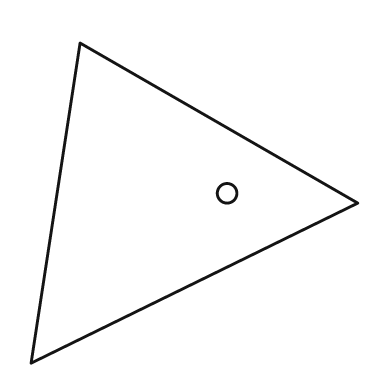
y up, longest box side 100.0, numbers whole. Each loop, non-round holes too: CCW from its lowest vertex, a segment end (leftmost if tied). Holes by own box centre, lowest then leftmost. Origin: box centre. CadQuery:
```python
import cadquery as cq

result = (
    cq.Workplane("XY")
    .moveTo(-50.0, -49.0)
    .lineTo(50.0, 0.0)
    .lineTo(-35.0, 49.0)
    .close()
    .moveTo(10.0, 3.0)
    .circle(3.0)
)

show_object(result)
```